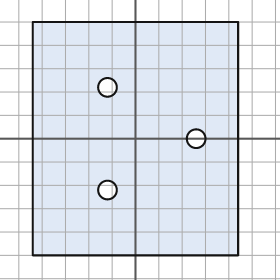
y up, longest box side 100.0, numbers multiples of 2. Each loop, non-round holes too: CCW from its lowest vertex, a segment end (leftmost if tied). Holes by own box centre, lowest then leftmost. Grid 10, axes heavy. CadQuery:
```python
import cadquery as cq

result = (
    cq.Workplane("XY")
    .moveTo(-44.0, -50.0)
    .lineTo(44.0, -50.0)
    .lineTo(44.0, 50.0)
    .lineTo(-44.0, 50.0)
    .close()
    .moveTo(-12.0, -22.0)
    .circle(4.0)
    .moveTo(26.0, 0.0)
    .circle(4.0)
    .moveTo(-12.0, 22.0)
    .circle(4.0)
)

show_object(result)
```